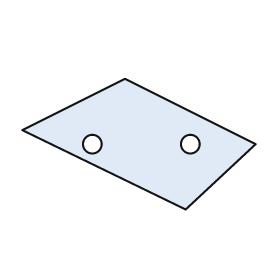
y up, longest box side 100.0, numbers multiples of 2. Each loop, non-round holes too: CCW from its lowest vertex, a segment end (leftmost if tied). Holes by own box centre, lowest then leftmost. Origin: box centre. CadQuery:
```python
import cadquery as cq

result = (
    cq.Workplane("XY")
    .moveTo(20.0, -28.0)
    .lineTo(50.0, 0.0)
    .lineTo(-6.0, 28.0)
    .lineTo(-50.0, 6.0)
    .close()
    .moveTo(-20.0, 0.0)
    .circle(4.0)
    .moveTo(22.0, 0.0)
    .circle(4.0)
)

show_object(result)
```